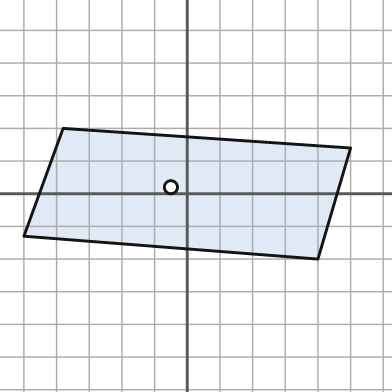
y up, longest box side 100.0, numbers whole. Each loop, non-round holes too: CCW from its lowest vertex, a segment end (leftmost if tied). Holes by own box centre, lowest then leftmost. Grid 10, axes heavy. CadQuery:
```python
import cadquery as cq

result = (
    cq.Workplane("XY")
    .moveTo(40.0, -20.0)
    .lineTo(50.0, 14.0)
    .lineTo(-38.0, 20.0)
    .lineTo(-50.0, -13.0)
    .close()
    .moveTo(-5.0, 2.0)
    .circle(2.0)
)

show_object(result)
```